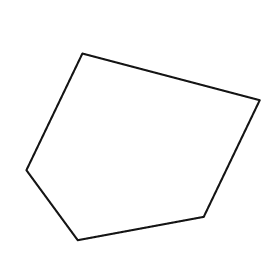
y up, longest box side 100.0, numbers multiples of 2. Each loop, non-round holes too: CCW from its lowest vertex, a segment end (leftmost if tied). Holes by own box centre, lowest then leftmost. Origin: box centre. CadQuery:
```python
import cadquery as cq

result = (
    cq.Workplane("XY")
    .moveTo(-28.0, -40.0)
    .lineTo(26.0, -30.0)
    .lineTo(50.0, 20.0)
    .lineTo(-26.0, 40.0)
    .lineTo(-50.0, -10.0)
    .close()
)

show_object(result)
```